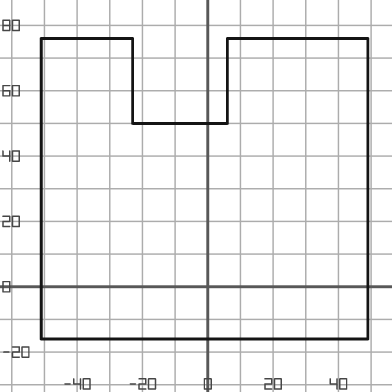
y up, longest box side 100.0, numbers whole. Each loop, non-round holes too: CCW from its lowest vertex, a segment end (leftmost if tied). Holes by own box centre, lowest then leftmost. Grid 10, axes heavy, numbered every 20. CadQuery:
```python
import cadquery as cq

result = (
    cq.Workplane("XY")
    .moveTo(-51.0, -16.0)
    .lineTo(49.0, -16.0)
    .lineTo(49.0, 76.0)
    .lineTo(6.0, 76.0)
    .lineTo(6.0, 50.0)
    .lineTo(-23.0, 50.0)
    .lineTo(-23.0, 76.0)
    .lineTo(-51.0, 76.0)
    .close()
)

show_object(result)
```